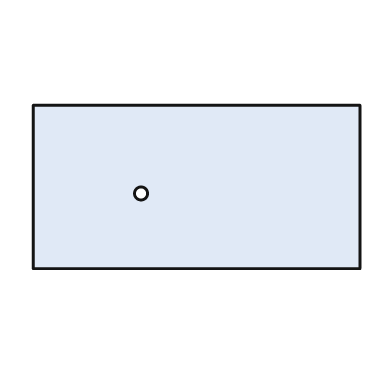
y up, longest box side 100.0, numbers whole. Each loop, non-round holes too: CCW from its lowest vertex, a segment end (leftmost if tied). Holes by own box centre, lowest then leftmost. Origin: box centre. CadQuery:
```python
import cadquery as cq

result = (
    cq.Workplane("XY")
    .moveTo(-50.0, -25.0)
    .lineTo(50.0, -25.0)
    .lineTo(50.0, 25.0)
    .lineTo(-50.0, 25.0)
    .close()
    .moveTo(-17.0, -2.0)
    .circle(2.0)
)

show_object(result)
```